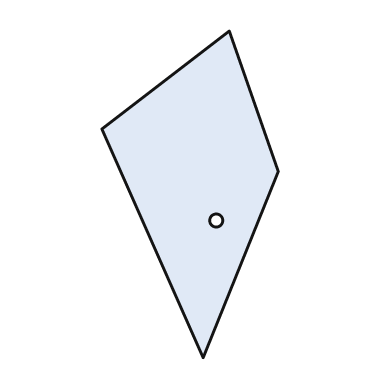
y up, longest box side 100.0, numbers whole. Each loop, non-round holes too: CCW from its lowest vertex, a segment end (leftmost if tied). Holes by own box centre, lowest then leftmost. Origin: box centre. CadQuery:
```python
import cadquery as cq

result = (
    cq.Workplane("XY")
    .moveTo(4.0, -50.0)
    .lineTo(27.0, 7.0)
    .lineTo(12.0, 50.0)
    .lineTo(-27.0, 20.0)
    .close()
    .moveTo(8.0, -8.0)
    .circle(2.0)
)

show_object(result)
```